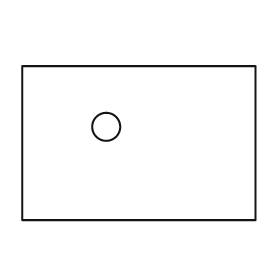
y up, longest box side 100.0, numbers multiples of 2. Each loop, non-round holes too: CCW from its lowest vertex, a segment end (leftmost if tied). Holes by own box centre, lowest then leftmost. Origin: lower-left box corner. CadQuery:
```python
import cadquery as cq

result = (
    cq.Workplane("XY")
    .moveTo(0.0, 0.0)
    .lineTo(100.0, 0.0)
    .lineTo(100.0, 66.0)
    .lineTo(0.0, 66.0)
    .close()
    .moveTo(36.0, 40.0)
    .circle(6.0)
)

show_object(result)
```